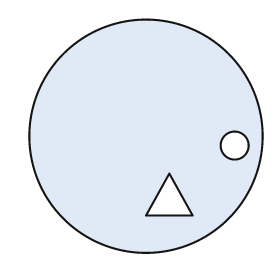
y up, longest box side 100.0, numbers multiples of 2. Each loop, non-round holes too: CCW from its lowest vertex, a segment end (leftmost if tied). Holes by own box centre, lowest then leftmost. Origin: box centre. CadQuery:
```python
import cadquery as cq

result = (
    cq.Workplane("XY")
    .moveTo(0.0, 0.0)
    .circle(50.0)
    .moveTo(0.0, -34.0)
    .lineTo(20.0, -34.0)
    .lineTo(10.0, -16.0)
    .close()
    .moveTo(38.0, -4.0)
    .circle(6.0)
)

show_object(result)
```